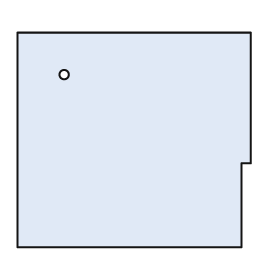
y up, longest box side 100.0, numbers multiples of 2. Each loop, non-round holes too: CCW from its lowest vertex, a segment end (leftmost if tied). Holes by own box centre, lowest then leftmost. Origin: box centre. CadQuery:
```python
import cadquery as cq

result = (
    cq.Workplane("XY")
    .moveTo(-50.0, -46.0)
    .lineTo(46.0, -46.0)
    .lineTo(46.0, -10.0)
    .lineTo(50.0, -10.0)
    .lineTo(50.0, 46.0)
    .lineTo(-50.0, 46.0)
    .close()
    .moveTo(-30.0, 28.0)
    .circle(2.0)
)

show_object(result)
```